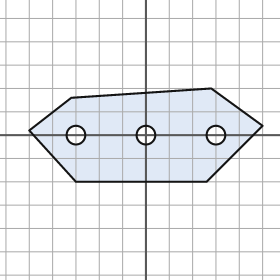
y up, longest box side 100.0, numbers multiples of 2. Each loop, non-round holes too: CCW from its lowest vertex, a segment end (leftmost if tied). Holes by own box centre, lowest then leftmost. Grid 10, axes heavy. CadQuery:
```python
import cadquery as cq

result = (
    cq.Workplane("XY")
    .moveTo(-30.0, -20.0)
    .lineTo(26.0, -20.0)
    .lineTo(50.0, 4.0)
    .lineTo(28.0, 20.0)
    .lineTo(-32.0, 16.0)
    .lineTo(-50.0, 2.0)
    .close()
    .moveTo(-30.0, 0.0)
    .circle(4.0)
    .moveTo(0.0, 0.0)
    .circle(4.0)
    .moveTo(30.0, 0.0)
    .circle(4.0)
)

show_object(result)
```